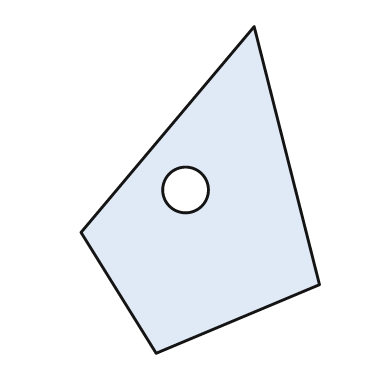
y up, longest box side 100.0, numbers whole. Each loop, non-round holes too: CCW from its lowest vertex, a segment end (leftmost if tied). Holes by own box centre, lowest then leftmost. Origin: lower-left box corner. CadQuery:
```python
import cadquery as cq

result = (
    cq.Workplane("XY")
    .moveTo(23.0, 0.0)
    .lineTo(73.0, 21.0)
    .lineTo(53.0, 100.0)
    .lineTo(0.0, 37.0)
    .close()
    .moveTo(32.0, 50.0)
    .circle(7.0)
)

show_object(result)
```